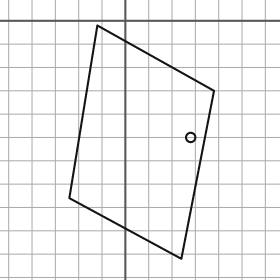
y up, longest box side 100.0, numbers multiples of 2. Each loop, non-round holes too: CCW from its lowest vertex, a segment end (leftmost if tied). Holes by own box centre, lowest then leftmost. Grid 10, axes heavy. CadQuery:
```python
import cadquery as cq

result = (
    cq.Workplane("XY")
    .moveTo(24.0, -102.0)
    .lineTo(38.0, -30.0)
    .lineTo(-12.0, -2.0)
    .lineTo(-24.0, -76.0)
    .close()
    .moveTo(28.0, -50.0)
    .circle(2.0)
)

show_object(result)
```